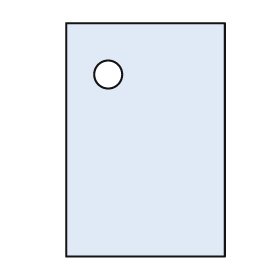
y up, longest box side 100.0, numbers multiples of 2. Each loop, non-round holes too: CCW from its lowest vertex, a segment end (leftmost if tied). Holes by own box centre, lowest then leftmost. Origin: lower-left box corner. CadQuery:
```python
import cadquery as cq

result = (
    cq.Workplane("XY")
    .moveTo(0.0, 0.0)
    .lineTo(68.0, 0.0)
    .lineTo(68.0, 100.0)
    .lineTo(0.0, 100.0)
    .close()
    .moveTo(18.0, 78.0)
    .circle(6.0)
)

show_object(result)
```